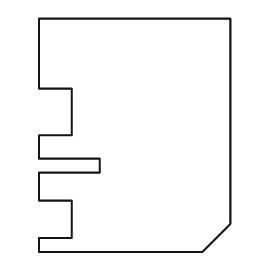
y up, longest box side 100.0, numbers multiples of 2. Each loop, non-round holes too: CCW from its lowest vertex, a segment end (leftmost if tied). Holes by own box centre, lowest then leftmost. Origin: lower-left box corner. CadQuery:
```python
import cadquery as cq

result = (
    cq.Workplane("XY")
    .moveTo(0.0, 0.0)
    .lineTo(70.0, 0.0)
    .lineTo(82.0, 12.0)
    .lineTo(82.0, 100.0)
    .lineTo(0.0, 100.0)
    .lineTo(0.0, 70.0)
    .lineTo(14.0, 70.0)
    .lineTo(14.0, 50.0)
    .lineTo(0.0, 50.0)
    .lineTo(0.0, 40.0)
    .lineTo(26.0, 40.0)
    .lineTo(26.0, 34.0)
    .lineTo(0.0, 34.0)
    .lineTo(0.0, 22.0)
    .lineTo(14.0, 22.0)
    .lineTo(14.0, 6.0)
    .lineTo(0.0, 6.0)
    .close()
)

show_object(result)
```